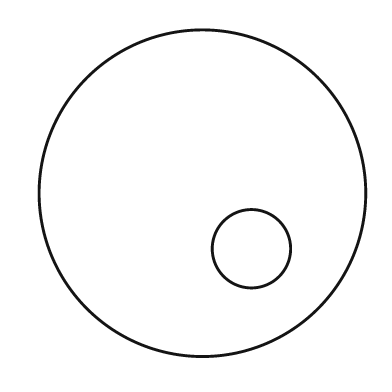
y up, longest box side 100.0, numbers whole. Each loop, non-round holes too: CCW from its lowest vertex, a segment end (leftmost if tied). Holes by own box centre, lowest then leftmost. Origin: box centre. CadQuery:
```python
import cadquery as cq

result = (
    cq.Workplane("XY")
    .moveTo(0.0, 0.0)
    .circle(50.0)
    .moveTo(15.0, -17.0)
    .circle(12.0)
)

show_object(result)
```